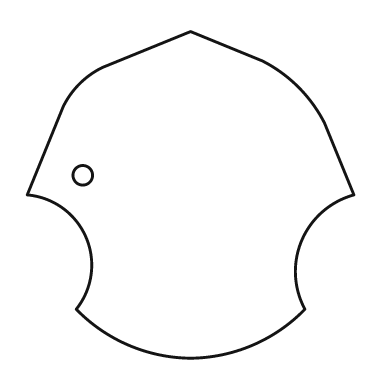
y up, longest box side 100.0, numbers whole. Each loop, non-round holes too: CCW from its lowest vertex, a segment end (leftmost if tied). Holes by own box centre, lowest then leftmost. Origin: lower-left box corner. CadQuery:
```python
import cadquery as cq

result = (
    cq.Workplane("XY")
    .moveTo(50.0, 0.0)
    .threePointArc((69.0, 4.0), (85.0, 15.0))
    .threePointArc((84.0, 36.0), (100.0, 50.0))
    .lineTo(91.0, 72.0)
    .threePointArc((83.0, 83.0), (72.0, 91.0))
    .lineTo(50.0, 100.0)
    .lineTo(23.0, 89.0)
    .threePointArc((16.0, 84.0), (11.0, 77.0))
    .lineTo(0.0, 50.0)
    .threePointArc((18.0, 37.0), (15.0, 15.0))
    .threePointArc((31.0, 4.0), (50.0, 0.0))
    .close()
    .moveTo(17.0, 56.0)
    .circle(3.0)
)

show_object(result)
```